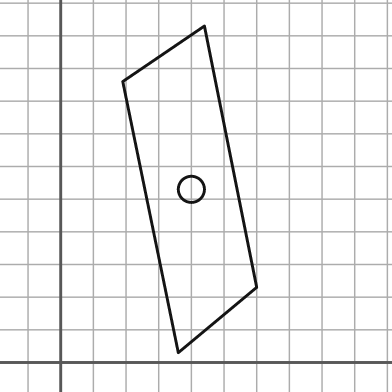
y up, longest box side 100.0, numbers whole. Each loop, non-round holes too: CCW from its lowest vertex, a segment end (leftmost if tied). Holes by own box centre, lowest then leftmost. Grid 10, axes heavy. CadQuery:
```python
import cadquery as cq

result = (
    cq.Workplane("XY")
    .moveTo(36.0, 3.0)
    .lineTo(60.0, 23.0)
    .lineTo(44.0, 103.0)
    .lineTo(19.0, 86.0)
    .close()
    .moveTo(40.0, 53.0)
    .circle(4.0)
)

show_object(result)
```